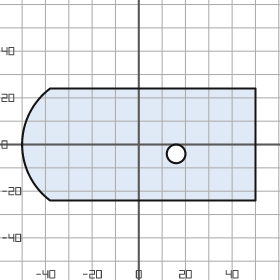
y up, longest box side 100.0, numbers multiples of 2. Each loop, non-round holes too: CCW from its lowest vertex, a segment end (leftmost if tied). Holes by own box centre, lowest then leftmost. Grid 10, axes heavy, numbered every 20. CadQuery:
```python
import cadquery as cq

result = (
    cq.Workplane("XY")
    .moveTo(-38.0, -24.0)
    .lineTo(50.0, -24.0)
    .lineTo(50.0, 24.0)
    .lineTo(-38.0, 24.0)
    .threePointArc((-50.0, 0.0), (-38.0, -24.0))
    .close()
    .moveTo(16.0, -4.0)
    .circle(4.0)
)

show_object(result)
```